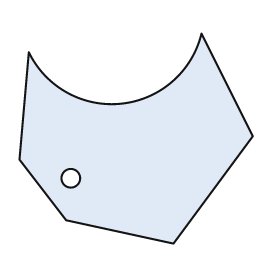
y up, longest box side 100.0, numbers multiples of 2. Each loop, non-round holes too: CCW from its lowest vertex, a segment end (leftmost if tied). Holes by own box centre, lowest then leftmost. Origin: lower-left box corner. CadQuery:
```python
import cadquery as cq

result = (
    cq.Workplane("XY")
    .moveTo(66.0, 0.0)
    .lineTo(100.0, 46.0)
    .lineTo(78.0, 90.0)
    .threePointArc((44.0, 60.0), (4.0, 82.0))
    .lineTo(0.0, 36.0)
    .lineTo(20.0, 10.0)
    .close()
    .moveTo(22.0, 28.0)
    .circle(4.0)
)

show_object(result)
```